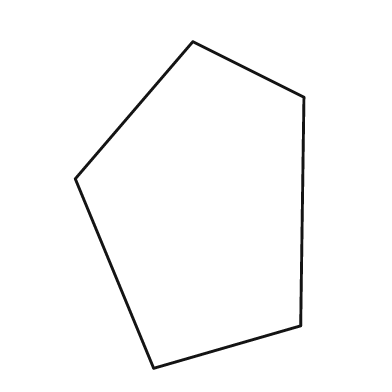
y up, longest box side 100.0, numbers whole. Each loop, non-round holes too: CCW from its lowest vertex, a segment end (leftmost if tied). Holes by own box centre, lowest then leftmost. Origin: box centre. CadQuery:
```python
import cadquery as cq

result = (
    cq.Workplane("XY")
    .moveTo(-11.0, -50.0)
    .lineTo(34.0, -37.0)
    .lineTo(35.0, 33.0)
    .lineTo(1.0, 50.0)
    .lineTo(-35.0, 8.0)
    .close()
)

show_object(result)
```